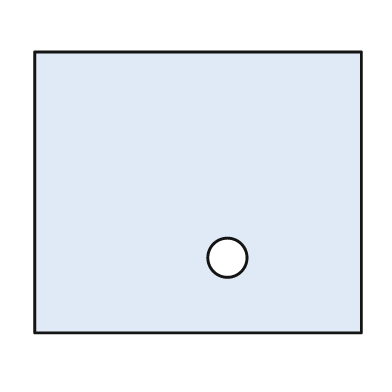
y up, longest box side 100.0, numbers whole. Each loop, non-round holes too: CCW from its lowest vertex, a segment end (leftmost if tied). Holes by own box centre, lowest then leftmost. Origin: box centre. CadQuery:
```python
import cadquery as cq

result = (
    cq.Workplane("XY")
    .moveTo(-50.0, -43.0)
    .lineTo(50.0, -43.0)
    .lineTo(50.0, 43.0)
    .lineTo(-50.0, 43.0)
    .close()
    .moveTo(9.0, -20.0)
    .circle(6.0)
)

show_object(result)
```